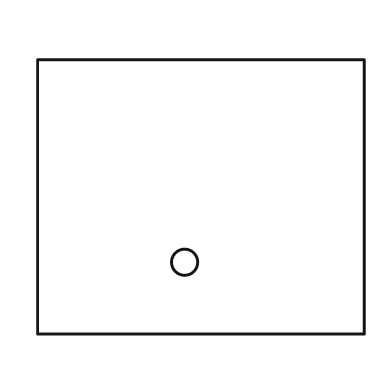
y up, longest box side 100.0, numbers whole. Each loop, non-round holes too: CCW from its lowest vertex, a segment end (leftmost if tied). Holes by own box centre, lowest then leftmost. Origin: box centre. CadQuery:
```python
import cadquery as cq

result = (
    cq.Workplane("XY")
    .moveTo(-50.0, -42.0)
    .lineTo(50.0, -42.0)
    .lineTo(50.0, 42.0)
    .lineTo(-50.0, 42.0)
    .close()
    .moveTo(-5.0, -20.0)
    .circle(4.0)
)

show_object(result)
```